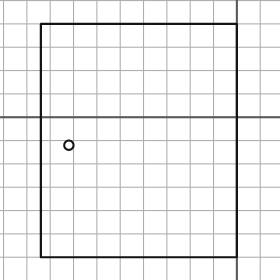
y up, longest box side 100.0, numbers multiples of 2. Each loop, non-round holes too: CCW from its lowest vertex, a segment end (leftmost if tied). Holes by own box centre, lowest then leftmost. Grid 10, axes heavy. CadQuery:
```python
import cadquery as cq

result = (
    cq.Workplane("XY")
    .moveTo(-84.0, -60.0)
    .lineTo(0.0, -60.0)
    .lineTo(0.0, 40.0)
    .lineTo(-84.0, 40.0)
    .close()
    .moveTo(-72.0, -12.0)
    .circle(2.0)
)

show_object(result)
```